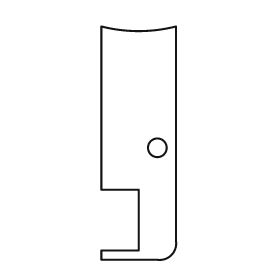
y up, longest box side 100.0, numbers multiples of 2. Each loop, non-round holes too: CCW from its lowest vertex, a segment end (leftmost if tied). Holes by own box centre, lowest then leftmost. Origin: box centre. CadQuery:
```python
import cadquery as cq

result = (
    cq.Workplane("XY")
    .moveTo(-16.0, -50.0)
    .lineTo(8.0, -50.0)
    .threePointArc((14.0, -48.0), (16.0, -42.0))
    .lineTo(16.0, 50.0)
    .threePointArc((0.0, 48.0), (-16.0, 50.0))
    .lineTo(-16.0, -20.0)
    .lineTo(0.0, -20.0)
    .lineTo(0.0, -46.0)
    .lineTo(-16.0, -46.0)
    .close()
    .moveTo(8.0, -2.0)
    .circle(4.0)
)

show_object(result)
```